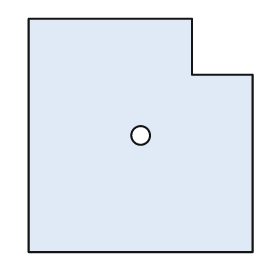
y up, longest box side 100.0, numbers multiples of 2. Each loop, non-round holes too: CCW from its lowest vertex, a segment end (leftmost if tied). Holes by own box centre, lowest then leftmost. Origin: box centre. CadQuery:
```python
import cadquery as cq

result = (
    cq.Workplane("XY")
    .moveTo(-48.0, -50.0)
    .lineTo(48.0, -50.0)
    .lineTo(48.0, 26.0)
    .lineTo(22.0, 26.0)
    .lineTo(22.0, 50.0)
    .lineTo(-48.0, 50.0)
    .close()
    .moveTo(0.0, 0.0)
    .circle(4.0)
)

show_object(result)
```